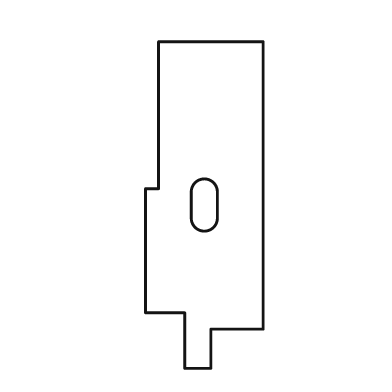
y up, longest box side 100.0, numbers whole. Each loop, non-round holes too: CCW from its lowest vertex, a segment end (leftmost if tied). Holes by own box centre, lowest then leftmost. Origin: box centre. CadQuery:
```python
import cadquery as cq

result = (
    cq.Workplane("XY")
    .moveTo(-6.0, -50.0)
    .lineTo(2.0, -50.0)
    .lineTo(2.0, -38.0)
    .lineTo(18.0, -38.0)
    .lineTo(18.0, 50.0)
    .lineTo(-14.0, 50.0)
    .lineTo(-14.0, 5.0)
    .lineTo(-18.0, 5.0)
    .lineTo(-18.0, -33.0)
    .lineTo(-6.0, -33.0)
    .close()
    .moveTo(-4.0, -4.0)
    .threePointArc((0.0, -8.0), (4.0, -4.0))
    .lineTo(4.0, 4.0)
    .threePointArc((0.0, 8.0), (-4.0, 4.0))
    .close()
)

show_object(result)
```